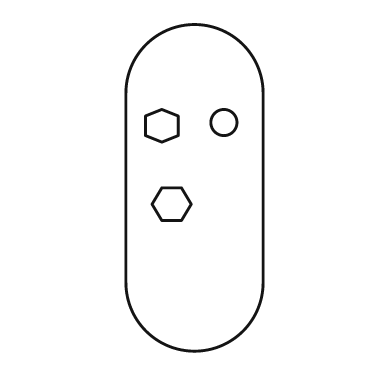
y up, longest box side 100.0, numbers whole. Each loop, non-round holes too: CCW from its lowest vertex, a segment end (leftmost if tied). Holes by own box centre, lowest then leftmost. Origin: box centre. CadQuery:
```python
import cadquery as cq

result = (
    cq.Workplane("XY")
    .moveTo(-21.0, -29.0)
    .threePointArc((0.0, -50.0), (21.0, -29.0))
    .lineTo(21.0, 29.0)
    .threePointArc((0.0, 50.0), (-21.0, 29.0))
    .close()
    .moveTo(-10.0, -10.0)
    .lineTo(-4.0, -10.0)
    .lineTo(-1.0, -5.0)
    .lineTo(-4.0, 0.0)
    .lineTo(-10.0, 0.0)
    .lineTo(-13.0, -5.0)
    .close()
    .moveTo(-10.0, 14.0)
    .lineTo(-5.0, 16.0)
    .lineTo(-5.0, 22.0)
    .lineTo(-10.0, 24.0)
    .lineTo(-15.0, 22.0)
    .lineTo(-15.0, 16.0)
    .close()
    .moveTo(9.0, 20.0)
    .circle(4.0)
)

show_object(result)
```